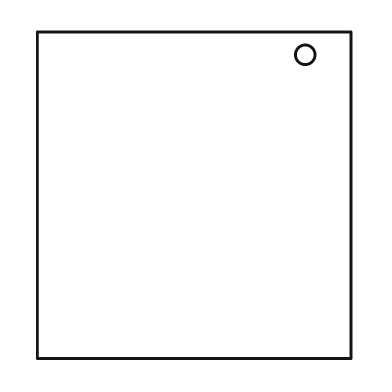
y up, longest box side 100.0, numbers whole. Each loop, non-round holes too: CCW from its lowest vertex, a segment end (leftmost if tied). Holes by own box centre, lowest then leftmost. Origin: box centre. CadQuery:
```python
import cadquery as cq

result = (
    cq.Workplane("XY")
    .moveTo(-48.0, -50.0)
    .lineTo(48.0, -50.0)
    .lineTo(48.0, 50.0)
    .lineTo(-48.0, 50.0)
    .close()
    .moveTo(34.0, 43.0)
    .circle(3.0)
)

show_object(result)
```